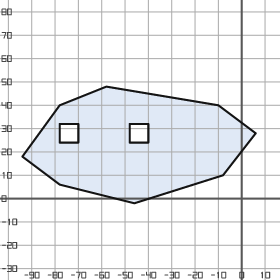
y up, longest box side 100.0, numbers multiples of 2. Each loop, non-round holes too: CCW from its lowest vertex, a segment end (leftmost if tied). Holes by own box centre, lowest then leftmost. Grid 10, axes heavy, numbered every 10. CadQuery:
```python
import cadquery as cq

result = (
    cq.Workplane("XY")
    .moveTo(-46.0, -2.0)
    .lineTo(-8.0, 10.0)
    .lineTo(6.0, 28.0)
    .lineTo(-10.0, 40.0)
    .lineTo(-58.0, 48.0)
    .lineTo(-78.0, 40.0)
    .lineTo(-94.0, 18.0)
    .lineTo(-78.0, 6.0)
    .close()
    .moveTo(-78.0, 24.0)
    .lineTo(-70.0, 24.0)
    .lineTo(-70.0, 32.0)
    .lineTo(-78.0, 32.0)
    .close()
    .moveTo(-48.0, 24.0)
    .lineTo(-40.0, 24.0)
    .lineTo(-40.0, 32.0)
    .lineTo(-48.0, 32.0)
    .close()
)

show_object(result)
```